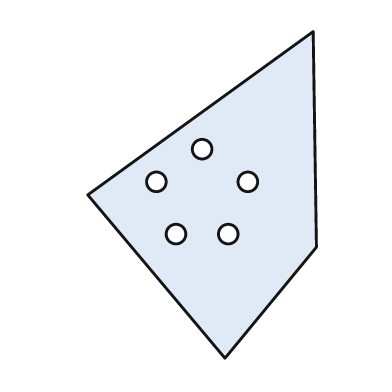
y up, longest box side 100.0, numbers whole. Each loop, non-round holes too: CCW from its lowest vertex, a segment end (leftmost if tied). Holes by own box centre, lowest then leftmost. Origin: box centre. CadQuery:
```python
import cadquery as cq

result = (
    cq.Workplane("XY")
    .moveTo(7.0, -50.0)
    .lineTo(35.0, -16.0)
    .lineTo(34.0, 50.0)
    .lineTo(-35.0, 0.0)
    .close()
    .moveTo(-8.0, -12.0)
    .circle(3.0)
    .moveTo(8.0, -12.0)
    .circle(3.0)
    .moveTo(-14.0, 4.0)
    .circle(3.0)
    .moveTo(14.0, 4.0)
    .circle(3.0)
    .moveTo(0.0, 14.0)
    .circle(3.0)
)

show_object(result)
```